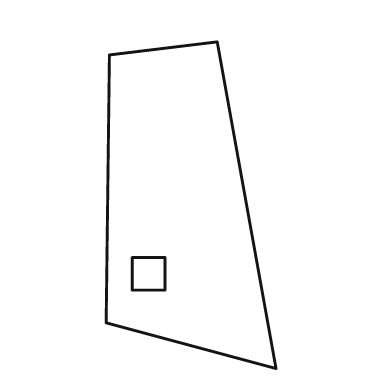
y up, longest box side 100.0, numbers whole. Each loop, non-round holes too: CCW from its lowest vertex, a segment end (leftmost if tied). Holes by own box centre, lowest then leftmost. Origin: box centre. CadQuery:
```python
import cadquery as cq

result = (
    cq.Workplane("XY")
    .moveTo(26.0, -50.0)
    .lineTo(8.0, 50.0)
    .lineTo(-25.0, 46.0)
    .lineTo(-26.0, -36.0)
    .close()
    .moveTo(-18.0, -26.0)
    .lineTo(-8.0, -26.0)
    .lineTo(-8.0, -16.0)
    .lineTo(-18.0, -16.0)
    .close()
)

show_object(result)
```